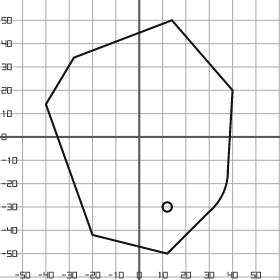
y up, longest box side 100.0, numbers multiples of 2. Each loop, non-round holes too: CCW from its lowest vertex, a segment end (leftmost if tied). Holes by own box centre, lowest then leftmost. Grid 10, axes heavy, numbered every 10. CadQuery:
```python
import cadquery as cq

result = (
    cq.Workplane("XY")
    .moveTo(12.0, -50.0)
    .lineTo(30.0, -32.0)
    .threePointArc((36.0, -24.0), (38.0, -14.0))
    .lineTo(40.0, 20.0)
    .lineTo(14.0, 50.0)
    .lineTo(-28.0, 34.0)
    .lineTo(-40.0, 14.0)
    .lineTo(-20.0, -42.0)
    .close()
    .moveTo(12.0, -30.0)
    .circle(2.0)
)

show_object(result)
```